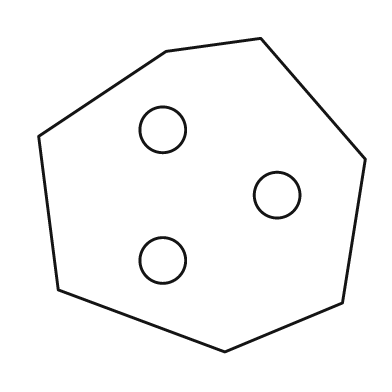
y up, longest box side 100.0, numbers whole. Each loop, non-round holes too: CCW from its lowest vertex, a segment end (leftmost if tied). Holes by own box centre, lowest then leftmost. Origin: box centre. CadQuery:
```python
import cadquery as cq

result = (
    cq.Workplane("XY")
    .moveTo(7.0, -48.0)
    .lineTo(43.0, -33.0)
    .lineTo(50.0, 11.0)
    .lineTo(18.0, 48.0)
    .lineTo(-11.0, 44.0)
    .lineTo(-50.0, 18.0)
    .lineTo(-44.0, -29.0)
    .close()
    .moveTo(-12.0, -20.0)
    .circle(7.0)
    .moveTo(23.0, 0.0)
    .circle(7.0)
    .moveTo(-12.0, 20.0)
    .circle(7.0)
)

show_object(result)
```